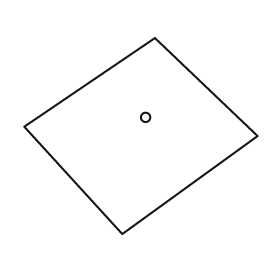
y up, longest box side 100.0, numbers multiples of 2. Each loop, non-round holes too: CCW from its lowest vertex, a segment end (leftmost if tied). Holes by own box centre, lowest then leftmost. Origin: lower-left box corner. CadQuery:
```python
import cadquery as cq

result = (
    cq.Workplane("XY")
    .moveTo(42.0, 0.0)
    .lineTo(100.0, 42.0)
    .lineTo(56.0, 84.0)
    .lineTo(0.0, 46.0)
    .close()
    .moveTo(52.0, 50.0)
    .circle(2.0)
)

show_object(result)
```